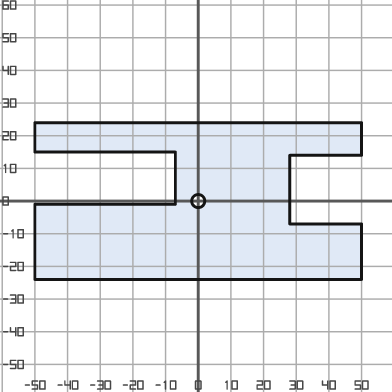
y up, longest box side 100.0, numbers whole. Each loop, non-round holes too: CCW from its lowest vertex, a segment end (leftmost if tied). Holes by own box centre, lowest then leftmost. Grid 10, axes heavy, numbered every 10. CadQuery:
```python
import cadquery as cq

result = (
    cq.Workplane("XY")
    .moveTo(-50.0, -24.0)
    .lineTo(50.0, -24.0)
    .lineTo(50.0, -7.0)
    .lineTo(28.0, -7.0)
    .lineTo(28.0, 14.0)
    .lineTo(50.0, 14.0)
    .lineTo(50.0, 24.0)
    .lineTo(-50.0, 24.0)
    .lineTo(-50.0, 15.0)
    .lineTo(-7.0, 15.0)
    .lineTo(-7.0, -1.0)
    .lineTo(-50.0, -1.0)
    .close()
    .moveTo(0.0, 0.0)
    .circle(2.0)
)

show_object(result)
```